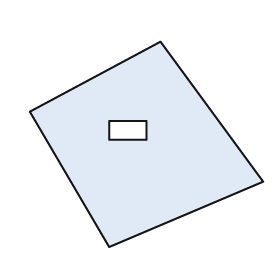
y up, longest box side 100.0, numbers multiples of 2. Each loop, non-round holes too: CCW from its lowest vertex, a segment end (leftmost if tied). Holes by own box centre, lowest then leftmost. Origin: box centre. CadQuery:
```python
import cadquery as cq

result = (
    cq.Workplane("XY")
    .moveTo(-16.0, -44.0)
    .lineTo(50.0, -16.0)
    .lineTo(6.0, 44.0)
    .lineTo(-50.0, 14.0)
    .close()
    .moveTo(-16.0, 2.0)
    .lineTo(0.0, 2.0)
    .lineTo(0.0, 10.0)
    .lineTo(-16.0, 10.0)
    .close()
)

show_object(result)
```